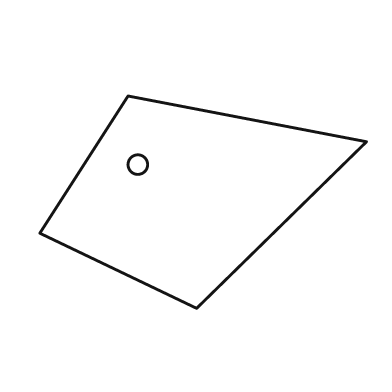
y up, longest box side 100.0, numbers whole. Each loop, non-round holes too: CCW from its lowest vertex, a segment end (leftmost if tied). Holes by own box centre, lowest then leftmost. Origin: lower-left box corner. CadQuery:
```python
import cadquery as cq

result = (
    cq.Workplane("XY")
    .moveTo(48.0, 0.0)
    .lineTo(100.0, 51.0)
    .lineTo(27.0, 65.0)
    .lineTo(0.0, 23.0)
    .close()
    .moveTo(30.0, 44.0)
    .circle(3.0)
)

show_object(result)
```